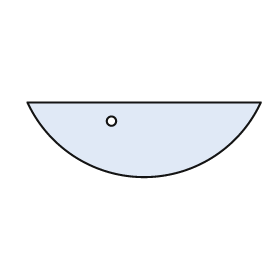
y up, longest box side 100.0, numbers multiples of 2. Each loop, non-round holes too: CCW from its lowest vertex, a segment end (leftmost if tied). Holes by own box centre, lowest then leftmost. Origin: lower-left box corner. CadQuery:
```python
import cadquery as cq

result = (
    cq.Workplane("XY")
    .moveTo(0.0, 32.0)
    .threePointArc((50.0, 0.0), (100.0, 32.0))
    .close()
    .moveTo(36.0, 24.0)
    .circle(2.0)
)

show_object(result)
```